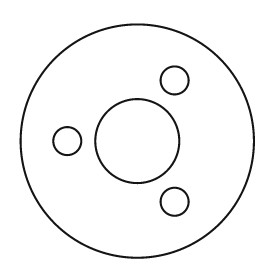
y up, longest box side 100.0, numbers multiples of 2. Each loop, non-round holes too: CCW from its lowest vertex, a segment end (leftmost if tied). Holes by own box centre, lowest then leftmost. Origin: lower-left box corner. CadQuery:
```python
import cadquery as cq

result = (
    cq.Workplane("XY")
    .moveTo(50.0, 50.0)
    .circle(50.0)
    .moveTo(66.0, 24.0)
    .circle(6.0)
    .moveTo(20.0, 50.0)
    .circle(6.0)
    .moveTo(50.0, 50.0)
    .circle(18.0)
    .moveTo(66.0, 76.0)
    .circle(6.0)
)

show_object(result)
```